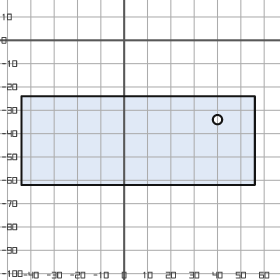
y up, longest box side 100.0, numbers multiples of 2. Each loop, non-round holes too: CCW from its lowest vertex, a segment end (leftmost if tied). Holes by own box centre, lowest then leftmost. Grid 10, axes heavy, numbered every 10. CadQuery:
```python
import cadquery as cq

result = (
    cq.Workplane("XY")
    .moveTo(-44.0, -62.0)
    .lineTo(56.0, -62.0)
    .lineTo(56.0, -24.0)
    .lineTo(-44.0, -24.0)
    .close()
    .moveTo(40.0, -34.0)
    .circle(2.0)
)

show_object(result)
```